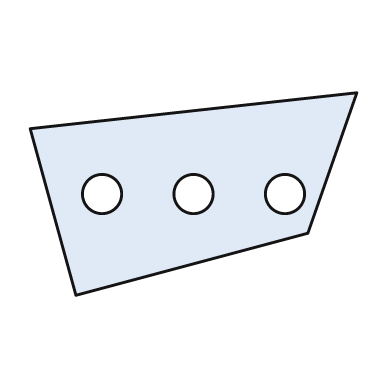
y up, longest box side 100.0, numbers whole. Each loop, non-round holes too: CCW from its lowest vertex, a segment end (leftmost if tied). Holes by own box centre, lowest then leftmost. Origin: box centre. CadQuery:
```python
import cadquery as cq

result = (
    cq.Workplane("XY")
    .moveTo(-36.0, -31.0)
    .lineTo(35.0, -12.0)
    .lineTo(50.0, 31.0)
    .lineTo(-50.0, 20.0)
    .close()
    .moveTo(-28.0, 0.0)
    .circle(6.0)
    .moveTo(0.0, 0.0)
    .circle(6.0)
    .moveTo(28.0, 0.0)
    .circle(6.0)
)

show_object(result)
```